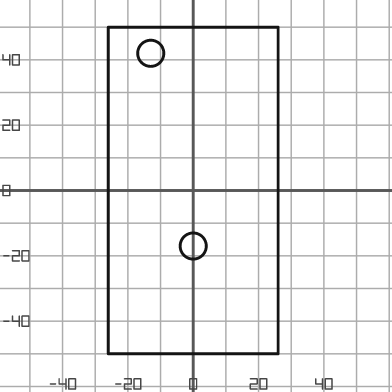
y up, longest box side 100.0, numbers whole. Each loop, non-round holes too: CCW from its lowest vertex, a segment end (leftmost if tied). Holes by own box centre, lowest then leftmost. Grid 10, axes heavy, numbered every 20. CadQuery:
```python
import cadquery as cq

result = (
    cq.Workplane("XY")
    .moveTo(-26.0, -50.0)
    .lineTo(26.0, -50.0)
    .lineTo(26.0, 50.0)
    .lineTo(-26.0, 50.0)
    .close()
    .moveTo(0.0, -17.0)
    .circle(4.0)
    .moveTo(-13.0, 42.0)
    .circle(4.0)
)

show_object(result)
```